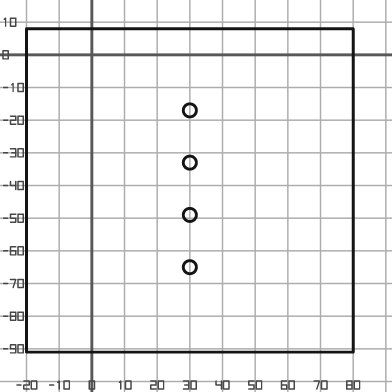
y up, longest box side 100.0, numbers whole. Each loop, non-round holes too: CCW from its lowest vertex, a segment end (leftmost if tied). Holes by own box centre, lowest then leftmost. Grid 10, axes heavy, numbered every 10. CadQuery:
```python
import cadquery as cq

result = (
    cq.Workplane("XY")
    .moveTo(-20.0, -91.0)
    .lineTo(80.0, -91.0)
    .lineTo(80.0, 8.0)
    .lineTo(-20.0, 8.0)
    .close()
    .moveTo(30.0, -65.0)
    .circle(2.0)
    .moveTo(30.0, -49.0)
    .circle(2.0)
    .moveTo(30.0, -33.0)
    .circle(2.0)
    .moveTo(30.0, -17.0)
    .circle(2.0)
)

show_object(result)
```